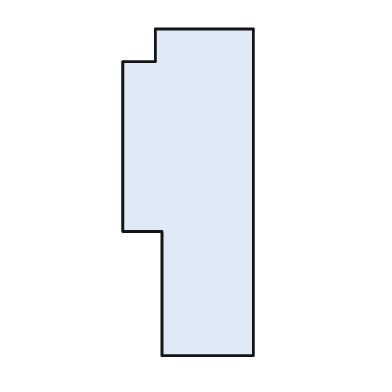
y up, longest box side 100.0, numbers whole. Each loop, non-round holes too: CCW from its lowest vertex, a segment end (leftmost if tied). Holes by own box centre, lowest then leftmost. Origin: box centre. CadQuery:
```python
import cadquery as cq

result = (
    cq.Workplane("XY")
    .moveTo(-8.0, -50.0)
    .lineTo(20.0, -50.0)
    .lineTo(20.0, 50.0)
    .lineTo(-10.0, 50.0)
    .lineTo(-10.0, 40.0)
    .lineTo(-20.0, 40.0)
    .lineTo(-20.0, -12.0)
    .lineTo(-8.0, -12.0)
    .close()
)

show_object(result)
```